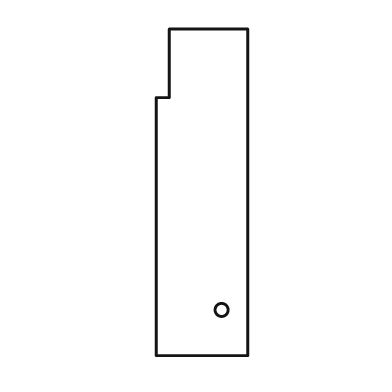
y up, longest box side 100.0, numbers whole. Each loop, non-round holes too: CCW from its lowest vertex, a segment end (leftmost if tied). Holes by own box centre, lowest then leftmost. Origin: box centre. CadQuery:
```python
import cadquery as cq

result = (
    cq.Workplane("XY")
    .moveTo(-14.0, -50.0)
    .lineTo(14.0, -50.0)
    .lineTo(14.0, 50.0)
    .lineTo(-10.0, 50.0)
    .lineTo(-10.0, 29.0)
    .lineTo(-14.0, 29.0)
    .close()
    .moveTo(6.0, -36.0)
    .circle(2.0)
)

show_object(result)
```